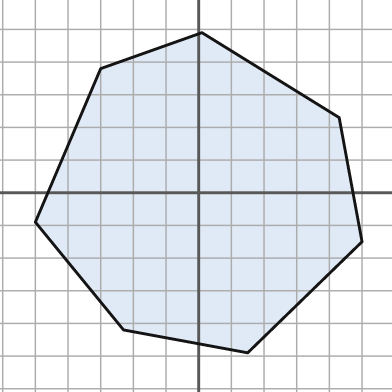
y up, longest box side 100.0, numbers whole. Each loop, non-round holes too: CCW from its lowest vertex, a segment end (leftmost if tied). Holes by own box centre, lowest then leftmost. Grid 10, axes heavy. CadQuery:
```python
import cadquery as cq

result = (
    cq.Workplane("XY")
    .moveTo(15.0, -49.0)
    .lineTo(50.0, -15.0)
    .lineTo(43.0, 23.0)
    .lineTo(1.0, 49.0)
    .lineTo(-30.0, 38.0)
    .lineTo(-50.0, -9.0)
    .lineTo(-23.0, -42.0)
    .close()
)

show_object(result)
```